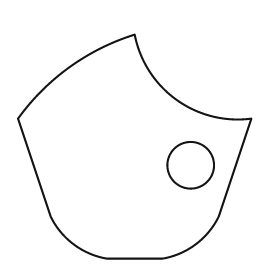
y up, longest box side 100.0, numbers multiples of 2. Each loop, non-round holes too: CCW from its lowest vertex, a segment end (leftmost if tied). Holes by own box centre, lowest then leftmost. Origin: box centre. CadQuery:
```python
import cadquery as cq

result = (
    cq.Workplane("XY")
    .moveTo(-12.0, -48.0)
    .lineTo(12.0, -48.0)
    .threePointArc((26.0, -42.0), (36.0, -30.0))
    .lineTo(50.0, 12.0)
    .threePointArc((18.0, 20.0), (0.0, 48.0))
    .threePointArc((-28.0, 34.0), (-50.0, 12.0))
    .lineTo(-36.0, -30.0)
    .threePointArc((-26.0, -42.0), (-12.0, -48.0))
    .close()
    .moveTo(24.0, -8.0)
    .circle(10.0)
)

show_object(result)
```